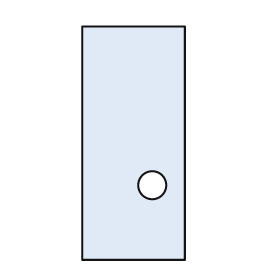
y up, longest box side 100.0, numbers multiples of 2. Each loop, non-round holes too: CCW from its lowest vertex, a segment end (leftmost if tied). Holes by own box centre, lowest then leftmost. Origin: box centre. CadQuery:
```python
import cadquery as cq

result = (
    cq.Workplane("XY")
    .moveTo(-22.0, -50.0)
    .lineTo(22.0, -50.0)
    .lineTo(22.0, 50.0)
    .lineTo(-22.0, 50.0)
    .close()
    .moveTo(8.0, -18.0)
    .circle(6.0)
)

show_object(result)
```